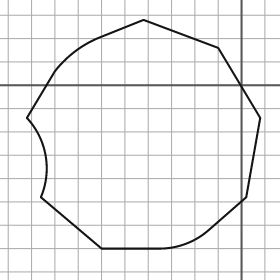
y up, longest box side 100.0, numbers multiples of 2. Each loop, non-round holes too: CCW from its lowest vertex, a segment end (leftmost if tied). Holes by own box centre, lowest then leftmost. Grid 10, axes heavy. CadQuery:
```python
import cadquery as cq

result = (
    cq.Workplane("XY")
    .moveTo(-60.0, -70.0)
    .lineTo(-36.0, -70.0)
    .threePointArc((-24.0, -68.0), (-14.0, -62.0))
    .lineTo(2.0, -48.0)
    .lineTo(8.0, -14.0)
    .lineTo(-10.0, 16.0)
    .lineTo(-42.0, 28.0)
    .lineTo(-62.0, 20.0)
    .threePointArc((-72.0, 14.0), (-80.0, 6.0))
    .lineTo(-92.0, -14.0)
    .threePointArc((-84.0, -30.0), (-86.0, -48.0))
    .close()
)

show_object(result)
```